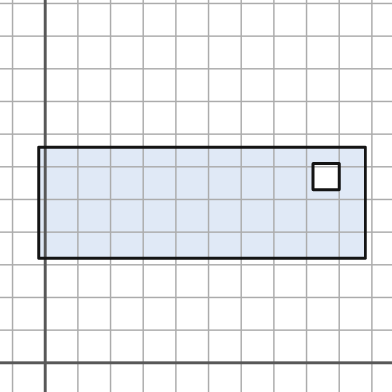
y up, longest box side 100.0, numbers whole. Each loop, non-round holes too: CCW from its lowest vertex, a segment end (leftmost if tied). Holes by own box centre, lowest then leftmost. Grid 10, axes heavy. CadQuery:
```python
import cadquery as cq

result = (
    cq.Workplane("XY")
    .moveTo(-2.0, 32.0)
    .lineTo(98.0, 32.0)
    .lineTo(98.0, 66.0)
    .lineTo(-2.0, 66.0)
    .close()
    .moveTo(82.0, 53.0)
    .lineTo(90.0, 53.0)
    .lineTo(90.0, 61.0)
    .lineTo(82.0, 61.0)
    .close()
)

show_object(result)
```